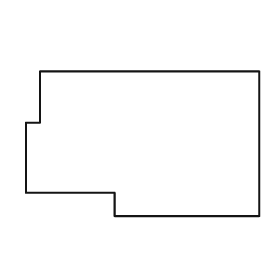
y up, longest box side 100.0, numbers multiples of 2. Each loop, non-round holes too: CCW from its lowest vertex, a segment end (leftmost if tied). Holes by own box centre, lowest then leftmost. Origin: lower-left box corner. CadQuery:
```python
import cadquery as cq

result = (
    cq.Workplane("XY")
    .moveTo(38.0, 0.0)
    .lineTo(100.0, 0.0)
    .lineTo(100.0, 62.0)
    .lineTo(6.0, 62.0)
    .lineTo(6.0, 40.0)
    .lineTo(0.0, 40.0)
    .lineTo(0.0, 10.0)
    .lineTo(38.0, 10.0)
    .close()
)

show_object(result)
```